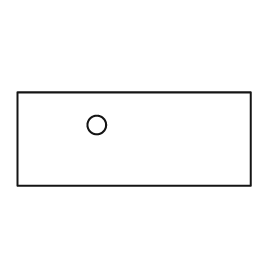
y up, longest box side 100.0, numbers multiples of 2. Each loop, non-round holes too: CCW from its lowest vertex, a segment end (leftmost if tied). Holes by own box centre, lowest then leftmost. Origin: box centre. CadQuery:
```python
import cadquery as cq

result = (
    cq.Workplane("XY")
    .moveTo(-50.0, -20.0)
    .lineTo(50.0, -20.0)
    .lineTo(50.0, 20.0)
    .lineTo(-50.0, 20.0)
    .close()
    .moveTo(-16.0, 6.0)
    .circle(4.0)
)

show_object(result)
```